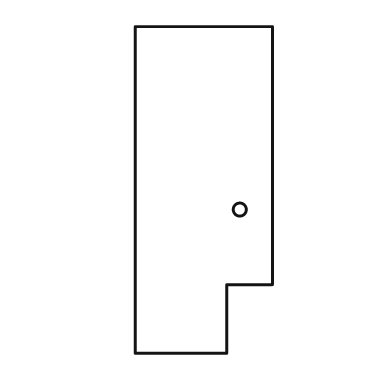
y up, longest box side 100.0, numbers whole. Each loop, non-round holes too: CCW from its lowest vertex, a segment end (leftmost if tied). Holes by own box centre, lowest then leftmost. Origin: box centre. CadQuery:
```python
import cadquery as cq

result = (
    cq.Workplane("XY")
    .moveTo(-21.0, -50.0)
    .lineTo(7.0, -50.0)
    .lineTo(7.0, -29.0)
    .lineTo(21.0, -29.0)
    .lineTo(21.0, 50.0)
    .lineTo(-21.0, 50.0)
    .close()
    .moveTo(11.0, -6.0)
    .circle(2.0)
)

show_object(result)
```